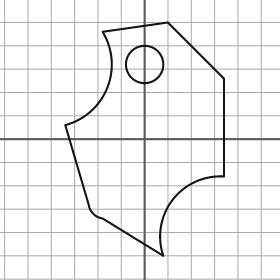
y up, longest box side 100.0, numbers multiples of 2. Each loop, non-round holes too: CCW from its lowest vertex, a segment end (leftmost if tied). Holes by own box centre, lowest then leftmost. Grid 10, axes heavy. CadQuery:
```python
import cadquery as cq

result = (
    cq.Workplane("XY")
    .moveTo(8.0, -50.0)
    .threePointArc((12.0, -26.0), (34.0, -16.0))
    .lineTo(34.0, 26.0)
    .lineTo(10.0, 50.0)
    .lineTo(-18.0, 46.0)
    .threePointArc((-16.0, 22.0), (-34.0, 6.0))
    .lineTo(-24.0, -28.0)
    .threePointArc((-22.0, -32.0), (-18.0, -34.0))
    .close()
    .moveTo(0.0, 32.0)
    .circle(8.0)
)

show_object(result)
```